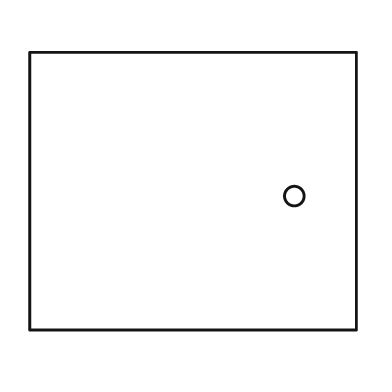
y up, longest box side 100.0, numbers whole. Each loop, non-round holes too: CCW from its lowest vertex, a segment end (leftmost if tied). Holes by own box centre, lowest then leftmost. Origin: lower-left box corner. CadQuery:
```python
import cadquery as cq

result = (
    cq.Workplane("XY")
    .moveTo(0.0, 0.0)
    .lineTo(100.0, 0.0)
    .lineTo(100.0, 85.0)
    .lineTo(0.0, 85.0)
    .close()
    .moveTo(81.0, 41.0)
    .circle(3.0)
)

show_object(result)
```